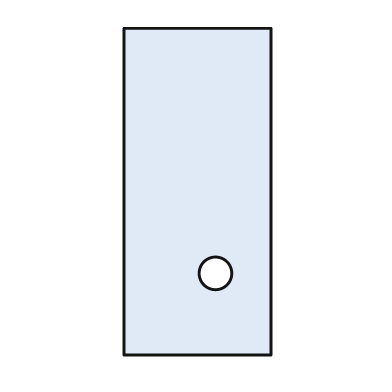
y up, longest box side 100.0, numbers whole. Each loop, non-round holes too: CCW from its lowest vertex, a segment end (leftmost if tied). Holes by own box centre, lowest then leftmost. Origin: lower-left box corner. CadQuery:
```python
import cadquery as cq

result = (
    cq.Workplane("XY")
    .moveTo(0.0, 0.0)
    .lineTo(45.0, 0.0)
    .lineTo(45.0, 100.0)
    .lineTo(0.0, 100.0)
    .close()
    .moveTo(28.0, 25.0)
    .circle(5.0)
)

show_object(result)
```